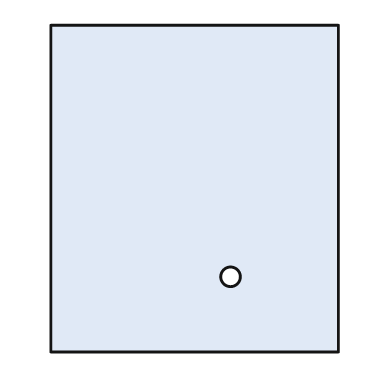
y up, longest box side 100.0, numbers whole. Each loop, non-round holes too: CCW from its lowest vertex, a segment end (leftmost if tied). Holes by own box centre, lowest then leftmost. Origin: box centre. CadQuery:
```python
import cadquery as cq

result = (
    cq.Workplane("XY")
    .moveTo(-44.0, -50.0)
    .lineTo(44.0, -50.0)
    .lineTo(44.0, 50.0)
    .lineTo(-44.0, 50.0)
    .close()
    .moveTo(11.0, -27.0)
    .circle(3.0)
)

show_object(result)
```